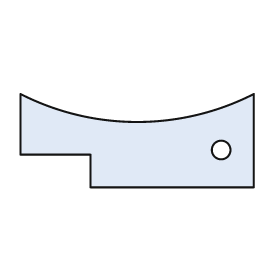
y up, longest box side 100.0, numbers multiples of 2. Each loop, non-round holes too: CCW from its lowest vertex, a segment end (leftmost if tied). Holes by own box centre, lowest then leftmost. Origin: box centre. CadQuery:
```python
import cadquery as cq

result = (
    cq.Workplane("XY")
    .moveTo(-20.0, -20.0)
    .lineTo(50.0, -20.0)
    .lineTo(50.0, 20.0)
    .threePointArc((0.0, 8.0), (-50.0, 20.0))
    .lineTo(-50.0, -6.0)
    .lineTo(-20.0, -6.0)
    .close()
    .moveTo(36.0, -4.0)
    .circle(4.0)
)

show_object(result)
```